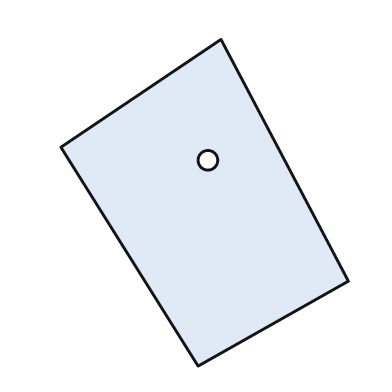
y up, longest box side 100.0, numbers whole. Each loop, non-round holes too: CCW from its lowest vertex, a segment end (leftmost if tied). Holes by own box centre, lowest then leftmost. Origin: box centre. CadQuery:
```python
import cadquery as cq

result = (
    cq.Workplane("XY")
    .moveTo(-2.0, -50.0)
    .lineTo(44.0, -24.0)
    .lineTo(5.0, 50.0)
    .lineTo(-44.0, 17.0)
    .close()
    .moveTo(1.0, 13.0)
    .circle(3.0)
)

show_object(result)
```